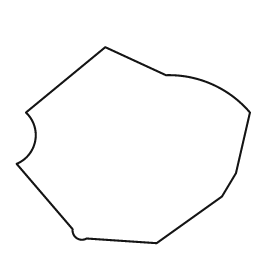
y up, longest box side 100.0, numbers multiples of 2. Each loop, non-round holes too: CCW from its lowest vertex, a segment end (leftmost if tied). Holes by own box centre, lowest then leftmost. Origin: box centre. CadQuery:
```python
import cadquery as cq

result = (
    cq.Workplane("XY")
    .moveTo(10.0, -42.0)
    .lineTo(38.0, -22.0)
    .lineTo(44.0, -12.0)
    .lineTo(50.0, 14.0)
    .threePointArc((34.0, 26.0), (14.0, 30.0))
    .lineTo(-12.0, 42.0)
    .lineTo(-46.0, 14.0)
    .threePointArc((-42.0, 2.0), (-50.0, -8.0))
    .lineTo(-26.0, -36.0)
    .threePointArc((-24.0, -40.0), (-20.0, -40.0))
    .close()
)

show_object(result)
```